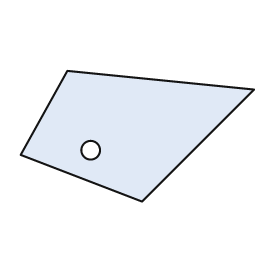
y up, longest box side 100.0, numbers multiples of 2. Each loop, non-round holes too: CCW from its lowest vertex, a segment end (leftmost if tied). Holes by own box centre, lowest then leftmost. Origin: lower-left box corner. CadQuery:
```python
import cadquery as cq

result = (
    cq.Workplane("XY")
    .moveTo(52.0, 0.0)
    .lineTo(100.0, 48.0)
    .lineTo(20.0, 56.0)
    .lineTo(0.0, 20.0)
    .close()
    .moveTo(30.0, 22.0)
    .circle(4.0)
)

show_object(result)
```